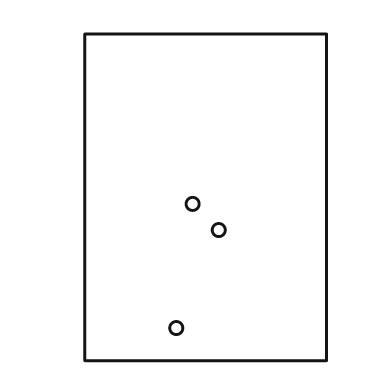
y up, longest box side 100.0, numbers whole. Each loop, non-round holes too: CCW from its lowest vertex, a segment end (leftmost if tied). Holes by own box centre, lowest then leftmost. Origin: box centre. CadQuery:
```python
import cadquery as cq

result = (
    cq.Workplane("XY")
    .moveTo(-37.0, -50.0)
    .lineTo(37.0, -50.0)
    .lineTo(37.0, 50.0)
    .lineTo(-37.0, 50.0)
    .close()
    .moveTo(-9.0, -40.0)
    .circle(2.0)
    .moveTo(4.0, -10.0)
    .circle(2.0)
    .moveTo(-4.0, -2.0)
    .circle(2.0)
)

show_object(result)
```